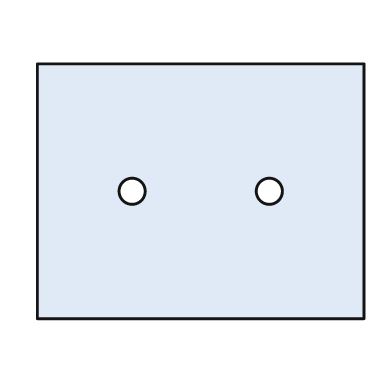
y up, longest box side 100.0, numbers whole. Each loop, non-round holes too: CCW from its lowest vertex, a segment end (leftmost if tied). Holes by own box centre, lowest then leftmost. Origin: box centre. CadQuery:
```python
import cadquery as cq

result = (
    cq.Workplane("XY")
    .moveTo(-50.0, -39.0)
    .lineTo(50.0, -39.0)
    .lineTo(50.0, 39.0)
    .lineTo(-50.0, 39.0)
    .close()
    .moveTo(-21.0, 0.0)
    .circle(4.0)
    .moveTo(21.0, 0.0)
    .circle(4.0)
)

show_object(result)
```